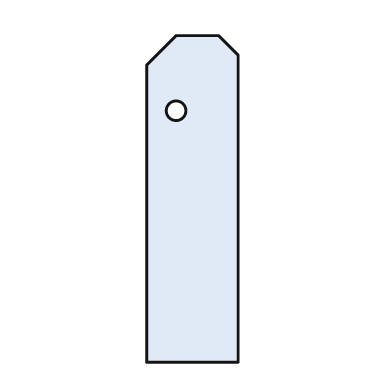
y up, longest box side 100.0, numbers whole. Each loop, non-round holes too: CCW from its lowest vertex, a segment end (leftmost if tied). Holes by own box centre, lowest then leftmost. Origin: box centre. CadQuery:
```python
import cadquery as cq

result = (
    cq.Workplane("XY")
    .moveTo(-14.0, -50.0)
    .lineTo(14.0, -50.0)
    .lineTo(14.0, 44.0)
    .lineTo(8.0, 50.0)
    .lineTo(-5.0, 50.0)
    .lineTo(-14.0, 41.0)
    .close()
    .moveTo(-5.0, 27.0)
    .circle(3.0)
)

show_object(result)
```